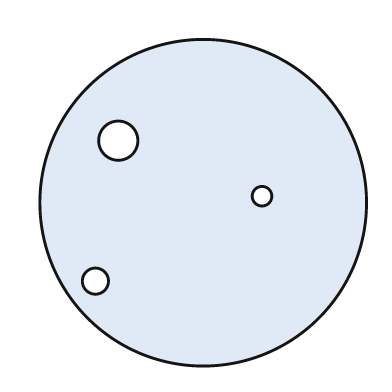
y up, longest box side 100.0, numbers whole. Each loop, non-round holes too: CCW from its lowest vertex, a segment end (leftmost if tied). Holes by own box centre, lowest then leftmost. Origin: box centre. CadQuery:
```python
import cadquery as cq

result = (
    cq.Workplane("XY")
    .moveTo(0.0, 0.0)
    .circle(50.0)
    .moveTo(-33.0, -24.0)
    .circle(4.0)
    .moveTo(18.0, 2.0)
    .circle(3.0)
    .moveTo(-26.0, 19.0)
    .circle(6.0)
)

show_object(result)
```